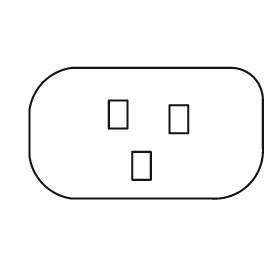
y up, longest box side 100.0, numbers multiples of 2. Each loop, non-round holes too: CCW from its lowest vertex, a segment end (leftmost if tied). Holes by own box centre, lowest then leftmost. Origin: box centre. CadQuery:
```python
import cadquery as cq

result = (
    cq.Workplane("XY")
    .moveTo(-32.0, -28.0)
    .lineTo(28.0, -28.0)
    .threePointArc((44.0, -22.0), (50.0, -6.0))
    .lineTo(50.0, 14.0)
    .threePointArc((46.0, 24.0), (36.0, 28.0))
    .lineTo(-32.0, 28.0)
    .threePointArc((-44.0, 22.0), (-50.0, 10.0))
    .lineTo(-50.0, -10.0)
    .threePointArc((-44.0, -22.0), (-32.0, -28.0))
    .close()
    .moveTo(-6.0, -20.0)
    .lineTo(2.0, -20.0)
    .lineTo(2.0, -8.0)
    .lineTo(-6.0, -8.0)
    .close()
    .moveTo(10.0, 0.0)
    .lineTo(18.0, 0.0)
    .lineTo(18.0, 12.0)
    .lineTo(10.0, 12.0)
    .close()
    .moveTo(-16.0, 2.0)
    .lineTo(-8.0, 2.0)
    .lineTo(-8.0, 14.0)
    .lineTo(-16.0, 14.0)
    .close()
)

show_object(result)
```